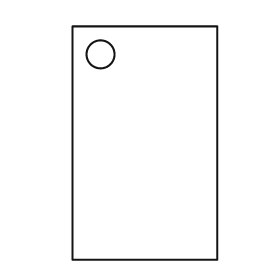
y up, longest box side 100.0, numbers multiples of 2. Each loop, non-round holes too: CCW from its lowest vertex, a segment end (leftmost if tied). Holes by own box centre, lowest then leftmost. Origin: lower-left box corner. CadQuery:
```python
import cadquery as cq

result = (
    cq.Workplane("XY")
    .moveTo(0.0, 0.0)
    .lineTo(62.0, 0.0)
    .lineTo(62.0, 100.0)
    .lineTo(0.0, 100.0)
    .close()
    .moveTo(12.0, 88.0)
    .circle(6.0)
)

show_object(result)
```